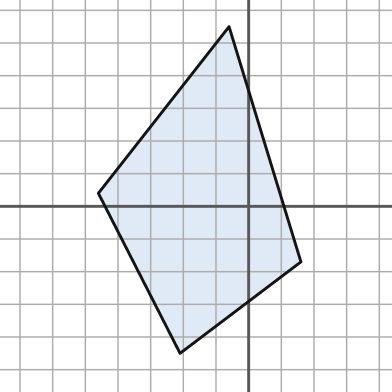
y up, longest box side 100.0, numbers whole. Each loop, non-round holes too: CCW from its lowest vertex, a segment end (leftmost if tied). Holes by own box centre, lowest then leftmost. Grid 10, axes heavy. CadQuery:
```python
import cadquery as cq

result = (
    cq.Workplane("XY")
    .moveTo(-21.0, -45.0)
    .lineTo(16.0, -17.0)
    .lineTo(-6.0, 55.0)
    .lineTo(-46.0, 4.0)
    .close()
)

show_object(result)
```